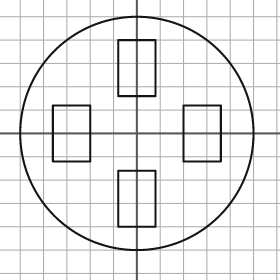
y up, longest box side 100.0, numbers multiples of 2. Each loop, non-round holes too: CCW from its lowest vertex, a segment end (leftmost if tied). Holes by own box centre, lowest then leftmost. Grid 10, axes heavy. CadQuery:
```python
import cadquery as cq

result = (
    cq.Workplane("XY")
    .moveTo(0.0, 0.0)
    .circle(50.0)
    .moveTo(-8.0, -40.0)
    .lineTo(8.0, -40.0)
    .lineTo(8.0, -16.0)
    .lineTo(-8.0, -16.0)
    .close()
    .moveTo(-36.0, -12.0)
    .lineTo(-20.0, -12.0)
    .lineTo(-20.0, 12.0)
    .lineTo(-36.0, 12.0)
    .close()
    .moveTo(20.0, -12.0)
    .lineTo(36.0, -12.0)
    .lineTo(36.0, 12.0)
    .lineTo(20.0, 12.0)
    .close()
    .moveTo(-8.0, 16.0)
    .lineTo(8.0, 16.0)
    .lineTo(8.0, 40.0)
    .lineTo(-8.0, 40.0)
    .close()
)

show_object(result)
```